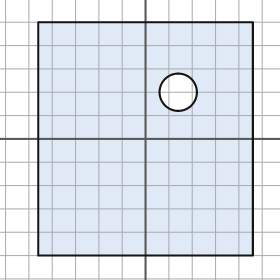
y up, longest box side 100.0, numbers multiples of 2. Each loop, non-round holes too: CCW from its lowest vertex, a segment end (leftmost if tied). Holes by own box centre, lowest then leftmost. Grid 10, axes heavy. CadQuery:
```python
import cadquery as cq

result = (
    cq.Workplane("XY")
    .moveTo(-46.0, -50.0)
    .lineTo(46.0, -50.0)
    .lineTo(46.0, 50.0)
    .lineTo(-46.0, 50.0)
    .close()
    .moveTo(14.0, 20.0)
    .circle(8.0)
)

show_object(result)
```